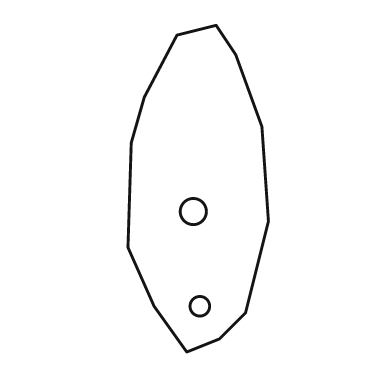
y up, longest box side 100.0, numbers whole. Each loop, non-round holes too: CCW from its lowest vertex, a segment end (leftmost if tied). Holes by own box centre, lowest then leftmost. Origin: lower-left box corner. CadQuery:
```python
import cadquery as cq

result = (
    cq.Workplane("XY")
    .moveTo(18.0, 0.0)
    .lineTo(28.0, 4.0)
    .lineTo(36.0, 12.0)
    .lineTo(43.0, 40.0)
    .lineTo(41.0, 69.0)
    .lineTo(33.0, 91.0)
    .lineTo(27.0, 100.0)
    .lineTo(15.0, 97.0)
    .lineTo(5.0, 78.0)
    .lineTo(1.0, 64.0)
    .lineTo(0.0, 32.0)
    .lineTo(8.0, 14.0)
    .close()
    .moveTo(22.0, 14.0)
    .circle(3.0)
    .moveTo(20.0, 43.0)
    .circle(4.0)
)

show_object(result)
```